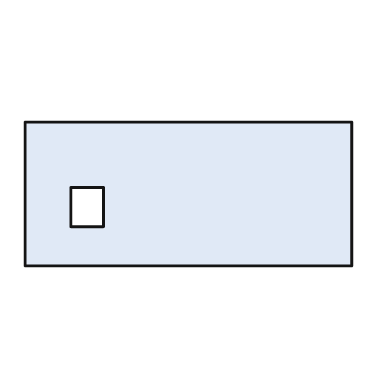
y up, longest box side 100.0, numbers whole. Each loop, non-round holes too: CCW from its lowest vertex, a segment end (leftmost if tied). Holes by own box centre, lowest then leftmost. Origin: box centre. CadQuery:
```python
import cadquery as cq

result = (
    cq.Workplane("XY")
    .moveTo(-50.0, -22.0)
    .lineTo(50.0, -22.0)
    .lineTo(50.0, 22.0)
    .lineTo(-50.0, 22.0)
    .close()
    .moveTo(-36.0, -10.0)
    .lineTo(-26.0, -10.0)
    .lineTo(-26.0, 2.0)
    .lineTo(-36.0, 2.0)
    .close()
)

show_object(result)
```